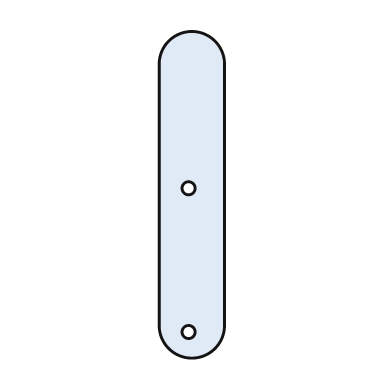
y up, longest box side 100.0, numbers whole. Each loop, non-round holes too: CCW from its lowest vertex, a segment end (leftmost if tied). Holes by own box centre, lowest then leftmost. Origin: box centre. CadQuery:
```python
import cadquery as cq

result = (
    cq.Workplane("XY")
    .moveTo(-10.0, -40.0)
    .threePointArc((0.0, -50.0), (10.0, -40.0))
    .lineTo(10.0, 40.0)
    .threePointArc((0.0, 50.0), (-10.0, 40.0))
    .close()
    .moveTo(-1.0, -42.0)
    .circle(2.0)
    .moveTo(-1.0, 2.0)
    .circle(2.0)
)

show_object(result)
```